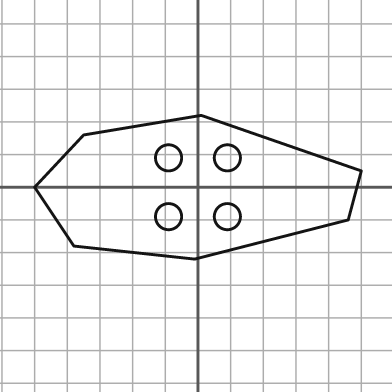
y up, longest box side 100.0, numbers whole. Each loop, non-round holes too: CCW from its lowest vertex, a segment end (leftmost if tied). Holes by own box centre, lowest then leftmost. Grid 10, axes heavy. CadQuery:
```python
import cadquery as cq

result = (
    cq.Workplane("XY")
    .moveTo(-1.0, -22.0)
    .lineTo(46.0, -10.0)
    .lineTo(50.0, 5.0)
    .lineTo(1.0, 22.0)
    .lineTo(-35.0, 16.0)
    .lineTo(-50.0, 0.0)
    .lineTo(-38.0, -18.0)
    .close()
    .moveTo(-9.0, -9.0)
    .circle(4.0)
    .moveTo(9.0, -9.0)
    .circle(4.0)
    .moveTo(-9.0, 9.0)
    .circle(4.0)
    .moveTo(9.0, 9.0)
    .circle(4.0)
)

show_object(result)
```